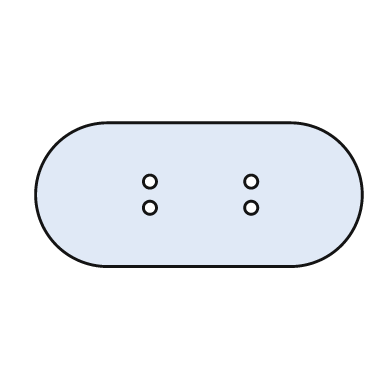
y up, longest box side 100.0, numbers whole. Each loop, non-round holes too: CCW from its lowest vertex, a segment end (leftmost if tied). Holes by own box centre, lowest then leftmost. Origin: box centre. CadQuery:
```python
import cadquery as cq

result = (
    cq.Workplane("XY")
    .moveTo(-28.0, -22.0)
    .lineTo(28.0, -22.0)
    .threePointArc((50.0, 0.0), (28.0, 22.0))
    .lineTo(-28.0, 22.0)
    .threePointArc((-50.0, 0.0), (-28.0, -22.0))
    .close()
    .moveTo(-15.0, -4.0)
    .circle(2.0)
    .moveTo(16.0, -4.0)
    .circle(2.0)
    .moveTo(-15.0, 4.0)
    .circle(2.0)
    .moveTo(16.0, 4.0)
    .circle(2.0)
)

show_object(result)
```